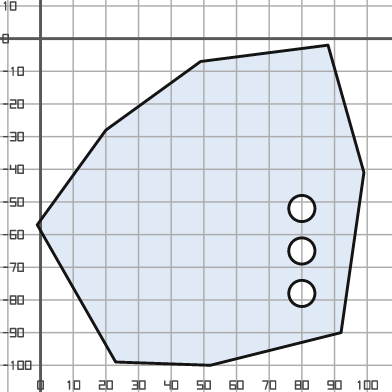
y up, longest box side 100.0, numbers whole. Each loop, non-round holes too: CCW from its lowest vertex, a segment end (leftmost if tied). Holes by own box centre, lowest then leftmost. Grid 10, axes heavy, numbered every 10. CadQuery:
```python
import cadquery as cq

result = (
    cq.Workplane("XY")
    .moveTo(52.0, -100.0)
    .lineTo(92.0, -90.0)
    .lineTo(99.0, -41.0)
    .lineTo(88.0, -2.0)
    .lineTo(49.0, -7.0)
    .lineTo(20.0, -28.0)
    .lineTo(-1.0, -57.0)
    .lineTo(23.0, -99.0)
    .close()
    .moveTo(80.0, -78.0)
    .circle(4.0)
    .moveTo(80.0, -65.0)
    .circle(4.0)
    .moveTo(80.0, -52.0)
    .circle(4.0)
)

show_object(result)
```